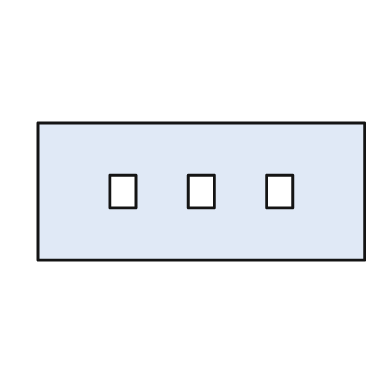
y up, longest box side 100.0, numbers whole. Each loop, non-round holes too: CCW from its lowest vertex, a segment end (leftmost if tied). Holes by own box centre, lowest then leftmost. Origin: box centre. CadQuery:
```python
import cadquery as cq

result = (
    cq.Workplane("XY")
    .moveTo(-50.0, -21.0)
    .lineTo(50.0, -21.0)
    .lineTo(50.0, 21.0)
    .lineTo(-50.0, 21.0)
    .close()
    .moveTo(-28.0, -5.0)
    .lineTo(-20.0, -5.0)
    .lineTo(-20.0, 5.0)
    .lineTo(-28.0, 5.0)
    .close()
    .moveTo(-4.0, -5.0)
    .lineTo(4.0, -5.0)
    .lineTo(4.0, 5.0)
    .lineTo(-4.0, 5.0)
    .close()
    .moveTo(20.0, -5.0)
    .lineTo(28.0, -5.0)
    .lineTo(28.0, 5.0)
    .lineTo(20.0, 5.0)
    .close()
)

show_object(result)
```